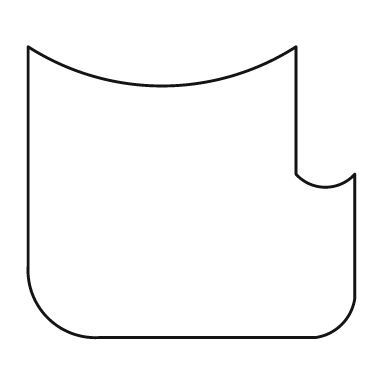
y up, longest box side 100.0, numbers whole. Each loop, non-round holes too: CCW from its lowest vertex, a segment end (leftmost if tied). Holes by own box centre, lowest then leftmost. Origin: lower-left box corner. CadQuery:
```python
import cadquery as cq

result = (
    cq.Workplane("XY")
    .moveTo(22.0, 0.0)
    .lineTo(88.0, 0.0)
    .threePointArc((96.0, 4.0), (100.0, 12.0))
    .lineTo(100.0, 50.0)
    .threePointArc((91.0, 46.0), (82.0, 50.0))
    .lineTo(82.0, 89.0)
    .threePointArc((41.0, 77.0), (0.0, 89.0))
    .lineTo(0.0, 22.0)
    .threePointArc((6.0, 6.0), (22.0, 0.0))
    .close()
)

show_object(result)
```